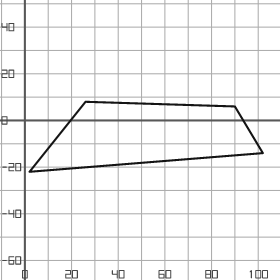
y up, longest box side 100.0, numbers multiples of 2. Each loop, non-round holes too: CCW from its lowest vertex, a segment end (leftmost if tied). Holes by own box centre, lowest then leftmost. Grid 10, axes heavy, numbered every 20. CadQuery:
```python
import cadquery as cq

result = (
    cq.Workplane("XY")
    .moveTo(2.0, -22.0)
    .lineTo(102.0, -14.0)
    .lineTo(90.0, 6.0)
    .lineTo(26.0, 8.0)
    .close()
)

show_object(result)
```